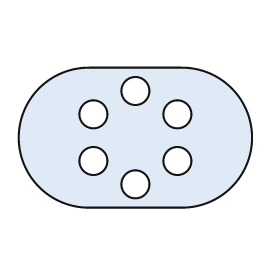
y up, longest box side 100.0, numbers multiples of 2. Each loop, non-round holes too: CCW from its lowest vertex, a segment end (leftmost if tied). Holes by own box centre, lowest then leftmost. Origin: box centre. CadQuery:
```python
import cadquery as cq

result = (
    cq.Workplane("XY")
    .moveTo(-20.0, -30.0)
    .lineTo(20.0, -30.0)
    .threePointArc((50.0, 0.0), (20.0, 30.0))
    .lineTo(-20.0, 30.0)
    .threePointArc((-50.0, 0.0), (-20.0, -30.0))
    .close()
    .moveTo(0.0, -20.0)
    .circle(6.0)
    .moveTo(-18.0, -10.0)
    .circle(6.0)
    .moveTo(18.0, -10.0)
    .circle(6.0)
    .moveTo(-18.0, 10.0)
    .circle(6.0)
    .moveTo(18.0, 10.0)
    .circle(6.0)
    .moveTo(0.0, 20.0)
    .circle(6.0)
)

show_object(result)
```